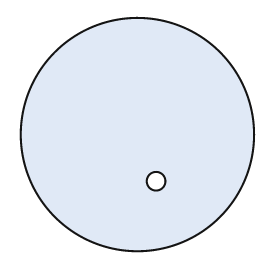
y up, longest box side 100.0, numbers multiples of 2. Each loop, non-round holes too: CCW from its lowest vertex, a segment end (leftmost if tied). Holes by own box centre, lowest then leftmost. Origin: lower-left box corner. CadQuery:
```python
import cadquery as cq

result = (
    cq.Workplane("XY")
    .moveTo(50.0, 50.0)
    .circle(50.0)
    .moveTo(58.0, 30.0)
    .circle(4.0)
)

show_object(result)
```